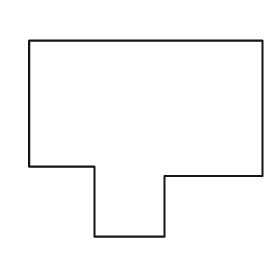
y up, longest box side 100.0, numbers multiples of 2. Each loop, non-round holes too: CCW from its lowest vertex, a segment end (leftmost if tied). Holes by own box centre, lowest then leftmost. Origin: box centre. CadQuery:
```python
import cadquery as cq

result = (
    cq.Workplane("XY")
    .moveTo(-22.0, -42.0)
    .lineTo(8.0, -42.0)
    .lineTo(8.0, -16.0)
    .lineTo(50.0, -16.0)
    .lineTo(50.0, 42.0)
    .lineTo(-50.0, 42.0)
    .lineTo(-50.0, -12.0)
    .lineTo(-22.0, -12.0)
    .close()
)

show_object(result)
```